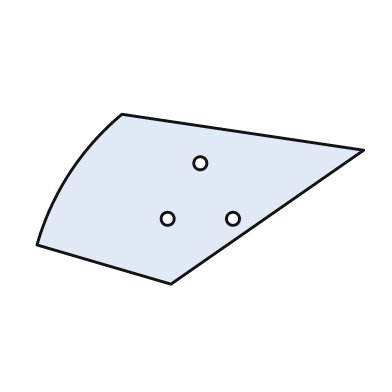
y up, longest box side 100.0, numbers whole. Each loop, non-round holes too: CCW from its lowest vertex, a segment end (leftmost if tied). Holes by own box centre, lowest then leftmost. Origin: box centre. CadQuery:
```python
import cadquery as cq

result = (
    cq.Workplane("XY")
    .moveTo(-9.0, -26.0)
    .lineTo(50.0, 15.0)
    .lineTo(-24.0, 26.0)
    .threePointArc((-40.0, 8.0), (-50.0, -14.0))
    .close()
    .moveTo(-10.0, -6.0)
    .circle(2.0)
    .moveTo(10.0, -6.0)
    .circle(2.0)
    .moveTo(0.0, 11.0)
    .circle(2.0)
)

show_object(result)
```